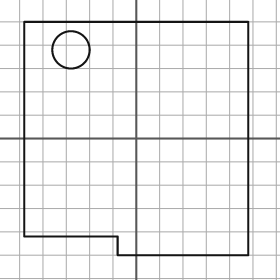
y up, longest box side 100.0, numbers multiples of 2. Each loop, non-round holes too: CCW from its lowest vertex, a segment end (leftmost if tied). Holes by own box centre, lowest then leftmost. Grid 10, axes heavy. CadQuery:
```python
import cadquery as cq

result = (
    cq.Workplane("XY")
    .moveTo(-8.0, -50.0)
    .lineTo(48.0, -50.0)
    .lineTo(48.0, 50.0)
    .lineTo(-48.0, 50.0)
    .lineTo(-48.0, -42.0)
    .lineTo(-8.0, -42.0)
    .close()
    .moveTo(-28.0, 38.0)
    .circle(8.0)
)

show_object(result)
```